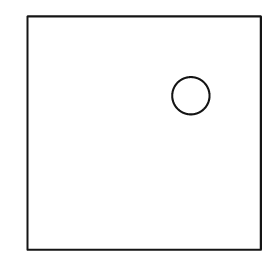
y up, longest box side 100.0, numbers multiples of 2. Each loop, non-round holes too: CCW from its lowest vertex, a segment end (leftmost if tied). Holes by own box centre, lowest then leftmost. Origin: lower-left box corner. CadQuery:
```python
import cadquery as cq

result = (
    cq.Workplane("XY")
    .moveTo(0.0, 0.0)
    .lineTo(100.0, 0.0)
    .lineTo(100.0, 100.0)
    .lineTo(0.0, 100.0)
    .close()
    .moveTo(70.0, 66.0)
    .circle(8.0)
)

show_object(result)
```